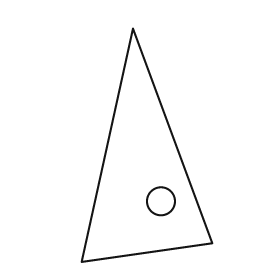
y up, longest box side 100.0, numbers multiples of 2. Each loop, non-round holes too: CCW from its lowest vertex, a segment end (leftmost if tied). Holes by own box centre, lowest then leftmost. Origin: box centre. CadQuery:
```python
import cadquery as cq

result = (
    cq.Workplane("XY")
    .moveTo(-28.0, -50.0)
    .lineTo(28.0, -42.0)
    .lineTo(-6.0, 50.0)
    .close()
    .moveTo(6.0, -24.0)
    .circle(6.0)
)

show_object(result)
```